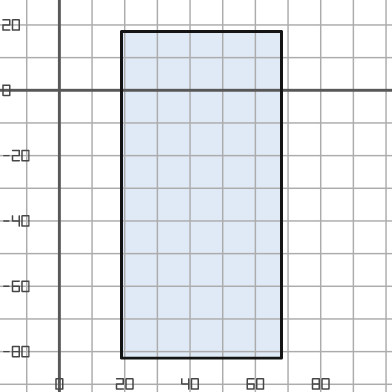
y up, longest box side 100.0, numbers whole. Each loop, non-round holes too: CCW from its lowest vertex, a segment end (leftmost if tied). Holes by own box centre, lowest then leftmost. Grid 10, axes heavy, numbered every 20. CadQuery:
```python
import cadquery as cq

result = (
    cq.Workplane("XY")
    .moveTo(19.0, -82.0)
    .lineTo(68.0, -82.0)
    .lineTo(68.0, 18.0)
    .lineTo(19.0, 18.0)
    .close()
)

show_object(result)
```